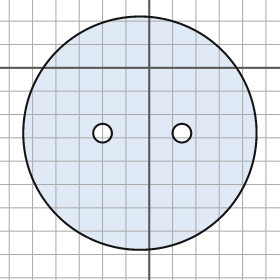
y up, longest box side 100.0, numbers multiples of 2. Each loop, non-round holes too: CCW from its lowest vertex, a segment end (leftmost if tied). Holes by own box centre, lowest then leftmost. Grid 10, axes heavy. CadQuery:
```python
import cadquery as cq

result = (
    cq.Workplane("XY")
    .moveTo(-4.0, -28.0)
    .circle(50.0)
    .moveTo(-20.0, -28.0)
    .circle(4.0)
    .moveTo(14.0, -28.0)
    .circle(4.0)
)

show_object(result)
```